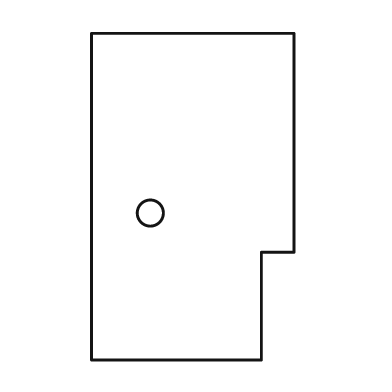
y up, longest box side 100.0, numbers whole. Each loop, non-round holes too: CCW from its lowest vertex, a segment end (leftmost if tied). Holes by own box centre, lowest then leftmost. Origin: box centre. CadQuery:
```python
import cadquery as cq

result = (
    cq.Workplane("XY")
    .moveTo(-31.0, -50.0)
    .lineTo(21.0, -50.0)
    .lineTo(21.0, -17.0)
    .lineTo(31.0, -17.0)
    .lineTo(31.0, 50.0)
    .lineTo(-31.0, 50.0)
    .close()
    .moveTo(-13.0, -5.0)
    .circle(4.0)
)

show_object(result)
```